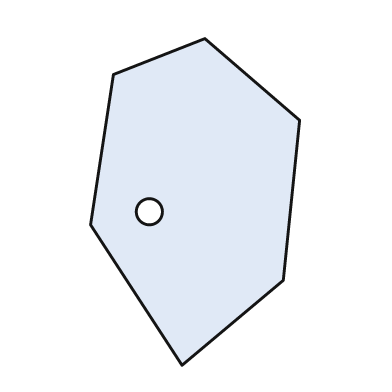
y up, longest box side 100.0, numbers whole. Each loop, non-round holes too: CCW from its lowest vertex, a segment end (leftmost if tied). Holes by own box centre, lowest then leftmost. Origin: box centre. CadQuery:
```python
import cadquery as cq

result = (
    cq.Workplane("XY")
    .moveTo(-4.0, -50.0)
    .lineTo(27.0, -24.0)
    .lineTo(32.0, 25.0)
    .lineTo(3.0, 50.0)
    .lineTo(-25.0, 39.0)
    .lineTo(-32.0, -7.0)
    .close()
    .moveTo(-14.0, -3.0)
    .circle(4.0)
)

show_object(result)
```